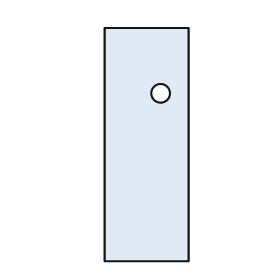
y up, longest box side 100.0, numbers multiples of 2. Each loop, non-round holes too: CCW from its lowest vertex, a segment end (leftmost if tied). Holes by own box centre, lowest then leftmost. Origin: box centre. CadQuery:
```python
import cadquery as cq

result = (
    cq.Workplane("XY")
    .moveTo(-18.0, -50.0)
    .lineTo(18.0, -50.0)
    .lineTo(18.0, 50.0)
    .lineTo(-18.0, 50.0)
    .close()
    .moveTo(6.0, 22.0)
    .circle(4.0)
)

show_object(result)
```